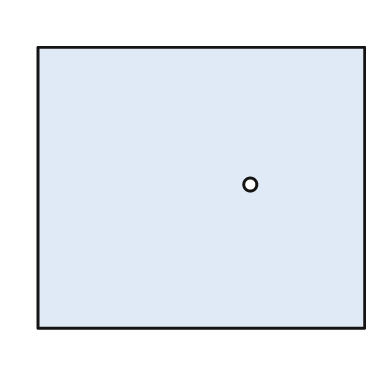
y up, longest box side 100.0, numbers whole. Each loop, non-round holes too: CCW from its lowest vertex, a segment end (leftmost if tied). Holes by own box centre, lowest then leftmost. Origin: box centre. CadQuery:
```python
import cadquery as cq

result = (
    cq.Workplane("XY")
    .moveTo(-50.0, -43.0)
    .lineTo(50.0, -43.0)
    .lineTo(50.0, 43.0)
    .lineTo(-50.0, 43.0)
    .close()
    .moveTo(15.0, 1.0)
    .circle(2.0)
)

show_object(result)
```